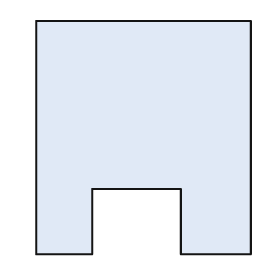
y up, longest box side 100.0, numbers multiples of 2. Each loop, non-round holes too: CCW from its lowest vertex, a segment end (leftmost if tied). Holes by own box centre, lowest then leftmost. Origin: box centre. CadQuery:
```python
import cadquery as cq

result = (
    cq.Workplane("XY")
    .moveTo(-46.0, -50.0)
    .lineTo(-22.0, -50.0)
    .lineTo(-22.0, -22.0)
    .lineTo(16.0, -22.0)
    .lineTo(16.0, -50.0)
    .lineTo(46.0, -50.0)
    .lineTo(46.0, 50.0)
    .lineTo(-46.0, 50.0)
    .close()
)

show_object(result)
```